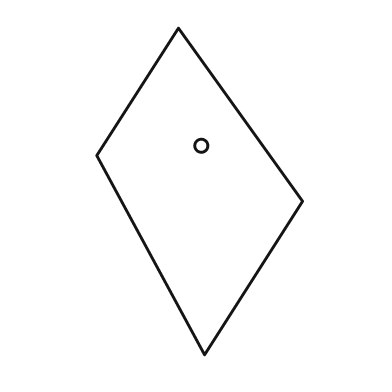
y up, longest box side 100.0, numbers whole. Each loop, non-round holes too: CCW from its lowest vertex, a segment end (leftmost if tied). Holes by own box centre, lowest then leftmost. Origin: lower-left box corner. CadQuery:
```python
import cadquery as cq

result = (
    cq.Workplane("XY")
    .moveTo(33.0, 0.0)
    .lineTo(63.0, 47.0)
    .lineTo(25.0, 100.0)
    .lineTo(0.0, 61.0)
    .close()
    .moveTo(32.0, 64.0)
    .circle(2.0)
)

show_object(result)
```